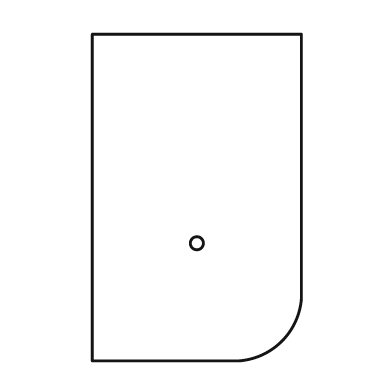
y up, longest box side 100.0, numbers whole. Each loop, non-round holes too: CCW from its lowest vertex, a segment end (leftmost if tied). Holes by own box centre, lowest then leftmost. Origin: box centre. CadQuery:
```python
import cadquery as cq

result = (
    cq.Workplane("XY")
    .moveTo(-32.0, -50.0)
    .lineTo(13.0, -50.0)
    .threePointArc((26.0, -44.0), (32.0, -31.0))
    .lineTo(32.0, 50.0)
    .lineTo(-32.0, 50.0)
    .close()
    .moveTo(0.0, -14.0)
    .circle(2.0)
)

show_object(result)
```